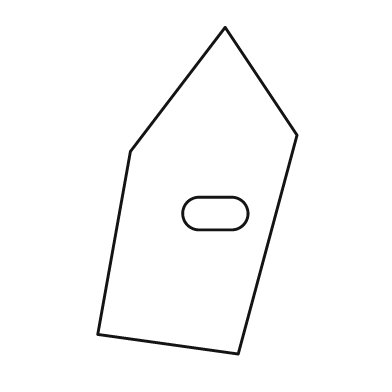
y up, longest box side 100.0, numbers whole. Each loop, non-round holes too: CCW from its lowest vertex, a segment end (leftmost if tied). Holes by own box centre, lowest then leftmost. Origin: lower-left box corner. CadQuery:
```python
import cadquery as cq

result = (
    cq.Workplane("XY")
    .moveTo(43.0, 0.0)
    .lineTo(61.0, 67.0)
    .lineTo(39.0, 100.0)
    .lineTo(10.0, 62.0)
    .lineTo(0.0, 6.0)
    .close()
    .moveTo(31.0, 38.0)
    .lineTo(41.0, 38.0)
    .threePointArc((46.0, 43.0), (41.0, 48.0))
    .lineTo(31.0, 48.0)
    .threePointArc((26.0, 43.0), (31.0, 38.0))
    .close()
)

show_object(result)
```